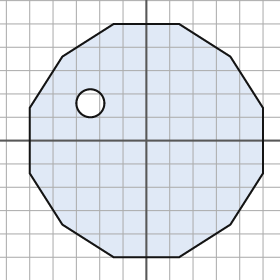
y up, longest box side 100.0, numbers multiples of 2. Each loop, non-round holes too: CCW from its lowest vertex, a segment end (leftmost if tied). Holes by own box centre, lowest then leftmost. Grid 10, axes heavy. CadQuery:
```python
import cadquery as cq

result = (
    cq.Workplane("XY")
    .moveTo(-14.0, -50.0)
    .lineTo(14.0, -50.0)
    .lineTo(36.0, -36.0)
    .lineTo(50.0, -14.0)
    .lineTo(50.0, 14.0)
    .lineTo(36.0, 36.0)
    .lineTo(14.0, 50.0)
    .lineTo(-14.0, 50.0)
    .lineTo(-36.0, 36.0)
    .lineTo(-50.0, 14.0)
    .lineTo(-50.0, -14.0)
    .lineTo(-36.0, -36.0)
    .close()
    .moveTo(-24.0, 16.0)
    .circle(6.0)
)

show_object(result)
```